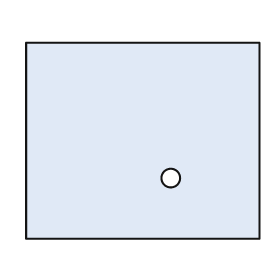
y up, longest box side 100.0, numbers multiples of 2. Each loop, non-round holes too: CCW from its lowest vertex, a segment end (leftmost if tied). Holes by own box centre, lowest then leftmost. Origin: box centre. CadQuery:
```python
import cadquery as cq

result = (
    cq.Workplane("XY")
    .moveTo(-50.0, -42.0)
    .lineTo(50.0, -42.0)
    .lineTo(50.0, 42.0)
    .lineTo(-50.0, 42.0)
    .close()
    .moveTo(12.0, -16.0)
    .circle(4.0)
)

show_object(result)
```